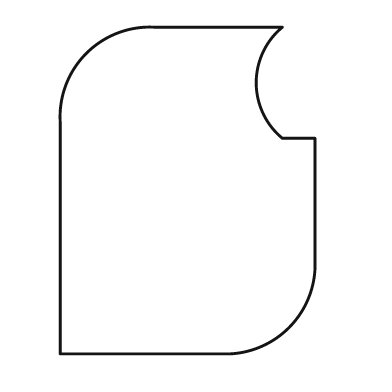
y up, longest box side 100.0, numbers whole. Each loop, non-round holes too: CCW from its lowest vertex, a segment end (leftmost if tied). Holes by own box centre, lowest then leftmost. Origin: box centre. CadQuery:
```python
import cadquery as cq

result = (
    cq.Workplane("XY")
    .moveTo(-39.0, -50.0)
    .lineTo(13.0, -50.0)
    .threePointArc((31.0, -42.0), (39.0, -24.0))
    .lineTo(39.0, 16.0)
    .lineTo(29.0, 16.0)
    .threePointArc((21.0, 33.0), (29.0, 50.0))
    .lineTo(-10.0, 50.0)
    .threePointArc((-31.0, 42.0), (-39.0, 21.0))
    .close()
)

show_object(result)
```